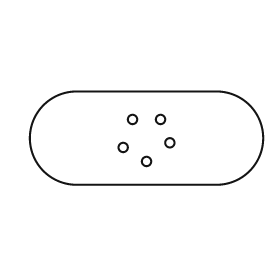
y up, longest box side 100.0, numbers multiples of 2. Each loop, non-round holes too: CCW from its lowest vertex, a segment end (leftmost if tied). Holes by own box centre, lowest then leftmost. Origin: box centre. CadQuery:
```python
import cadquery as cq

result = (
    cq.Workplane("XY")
    .moveTo(-30.0, -20.0)
    .lineTo(30.0, -20.0)
    .threePointArc((50.0, 0.0), (30.0, 20.0))
    .lineTo(-30.0, 20.0)
    .threePointArc((-50.0, 0.0), (-30.0, -20.0))
    .close()
    .moveTo(0.0, -10.0)
    .circle(2.0)
    .moveTo(-10.0, -4.0)
    .circle(2.0)
    .moveTo(10.0, -2.0)
    .circle(2.0)
    .moveTo(-6.0, 8.0)
    .circle(2.0)
    .moveTo(6.0, 8.0)
    .circle(2.0)
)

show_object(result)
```